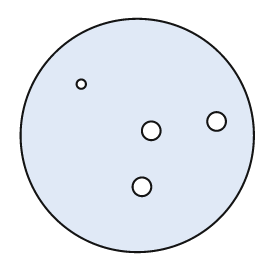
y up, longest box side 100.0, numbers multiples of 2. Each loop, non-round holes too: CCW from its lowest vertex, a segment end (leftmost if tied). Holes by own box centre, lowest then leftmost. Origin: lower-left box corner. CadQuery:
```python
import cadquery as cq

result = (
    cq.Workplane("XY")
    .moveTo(50.0, 50.0)
    .circle(50.0)
    .moveTo(52.0, 28.0)
    .circle(4.0)
    .moveTo(56.0, 52.0)
    .circle(4.0)
    .moveTo(84.0, 56.0)
    .circle(4.0)
    .moveTo(26.0, 72.0)
    .circle(2.0)
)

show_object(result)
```